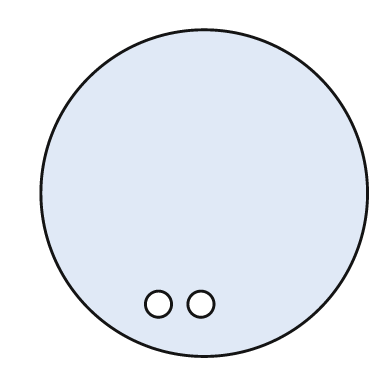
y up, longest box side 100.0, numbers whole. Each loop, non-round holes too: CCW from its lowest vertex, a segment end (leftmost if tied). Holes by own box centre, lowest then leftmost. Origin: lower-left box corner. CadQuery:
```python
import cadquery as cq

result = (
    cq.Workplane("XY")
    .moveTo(50.0, 50.0)
    .circle(50.0)
    .moveTo(36.0, 16.0)
    .circle(4.0)
    .moveTo(49.0, 16.0)
    .circle(4.0)
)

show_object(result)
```